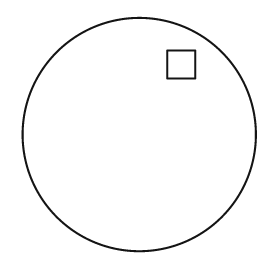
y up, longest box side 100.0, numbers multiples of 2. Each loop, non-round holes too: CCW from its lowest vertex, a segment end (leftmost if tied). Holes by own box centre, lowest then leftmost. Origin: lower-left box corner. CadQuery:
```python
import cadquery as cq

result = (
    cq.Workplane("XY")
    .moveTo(50.0, 50.0)
    .circle(50.0)
    .moveTo(62.0, 74.0)
    .lineTo(74.0, 74.0)
    .lineTo(74.0, 86.0)
    .lineTo(62.0, 86.0)
    .close()
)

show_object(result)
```